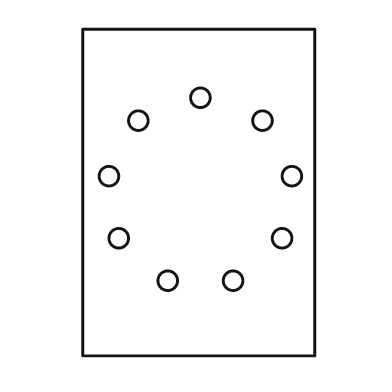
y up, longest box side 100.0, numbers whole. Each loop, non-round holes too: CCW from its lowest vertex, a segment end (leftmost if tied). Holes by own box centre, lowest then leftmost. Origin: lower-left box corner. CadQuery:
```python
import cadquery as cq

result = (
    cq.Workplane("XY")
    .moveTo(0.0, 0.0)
    .lineTo(71.0, 0.0)
    .lineTo(71.0, 100.0)
    .lineTo(0.0, 100.0)
    .close()
    .moveTo(26.0, 23.0)
    .circle(3.0)
    .moveTo(46.0, 23.0)
    .circle(3.0)
    .moveTo(11.0, 36.0)
    .circle(3.0)
    .moveTo(61.0, 36.0)
    .circle(3.0)
    .moveTo(8.0, 55.0)
    .circle(3.0)
    .moveTo(64.0, 55.0)
    .circle(3.0)
    .moveTo(17.0, 72.0)
    .circle(3.0)
    .moveTo(55.0, 72.0)
    .circle(3.0)
    .moveTo(36.0, 79.0)
    .circle(3.0)
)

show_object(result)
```